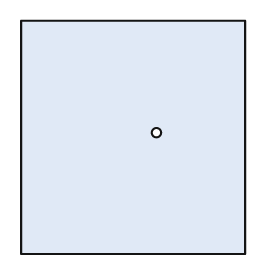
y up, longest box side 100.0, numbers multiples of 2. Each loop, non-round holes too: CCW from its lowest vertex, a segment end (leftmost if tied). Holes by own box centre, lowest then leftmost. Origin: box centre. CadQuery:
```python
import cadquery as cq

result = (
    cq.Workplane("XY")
    .moveTo(-48.0, -50.0)
    .lineTo(48.0, -50.0)
    .lineTo(48.0, 50.0)
    .lineTo(-48.0, 50.0)
    .close()
    .moveTo(10.0, 2.0)
    .circle(2.0)
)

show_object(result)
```